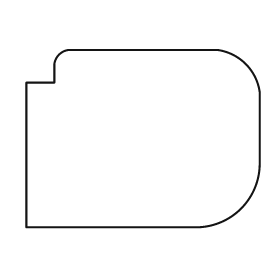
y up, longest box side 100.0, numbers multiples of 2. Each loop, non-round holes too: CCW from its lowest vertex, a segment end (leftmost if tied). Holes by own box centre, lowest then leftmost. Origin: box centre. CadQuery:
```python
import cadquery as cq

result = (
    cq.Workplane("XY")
    .moveTo(-50.0, -38.0)
    .lineTo(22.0, -38.0)
    .threePointArc((42.0, -30.0), (50.0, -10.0))
    .lineTo(50.0, 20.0)
    .threePointArc((44.0, 32.0), (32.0, 38.0))
    .lineTo(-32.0, 38.0)
    .threePointArc((-36.0, 36.0), (-38.0, 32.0))
    .lineTo(-38.0, 24.0)
    .lineTo(-50.0, 24.0)
    .close()
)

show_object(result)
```